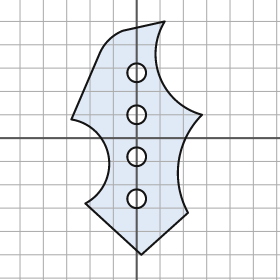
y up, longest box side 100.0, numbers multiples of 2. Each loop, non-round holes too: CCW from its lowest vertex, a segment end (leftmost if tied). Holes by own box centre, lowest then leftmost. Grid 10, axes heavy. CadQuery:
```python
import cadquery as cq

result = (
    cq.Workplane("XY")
    .moveTo(2.0, -50.0)
    .lineTo(22.0, -32.0)
    .threePointArc((18.0, -10.0), (28.0, 10.0))
    .threePointArc((10.0, 26.0), (12.0, 50.0))
    .lineTo(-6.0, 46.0)
    .threePointArc((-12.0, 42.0), (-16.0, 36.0))
    .lineTo(-28.0, 8.0)
    .threePointArc((-12.0, -8.0), (-22.0, -28.0))
    .close()
    .moveTo(0.0, -26.0)
    .circle(4.0)
    .moveTo(0.0, -8.0)
    .circle(4.0)
    .moveTo(0.0, 10.0)
    .circle(4.0)
    .moveTo(0.0, 28.0)
    .circle(4.0)
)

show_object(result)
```